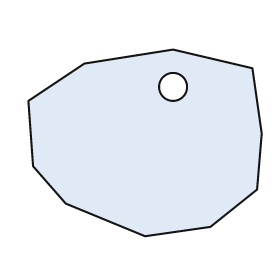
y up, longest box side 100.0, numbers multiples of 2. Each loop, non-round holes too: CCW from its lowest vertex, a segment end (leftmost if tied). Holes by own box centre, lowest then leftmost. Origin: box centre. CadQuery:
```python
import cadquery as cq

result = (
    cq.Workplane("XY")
    .moveTo(0.0, -40.0)
    .lineTo(28.0, -36.0)
    .lineTo(48.0, -20.0)
    .lineTo(50.0, 4.0)
    .lineTo(46.0, 32.0)
    .lineTo(12.0, 40.0)
    .lineTo(-26.0, 34.0)
    .lineTo(-50.0, 18.0)
    .lineTo(-48.0, -10.0)
    .lineTo(-34.0, -26.0)
    .close()
    .moveTo(12.0, 24.0)
    .circle(6.0)
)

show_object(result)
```